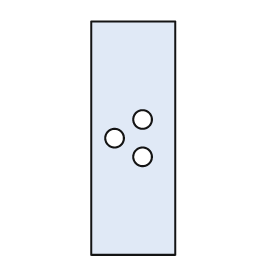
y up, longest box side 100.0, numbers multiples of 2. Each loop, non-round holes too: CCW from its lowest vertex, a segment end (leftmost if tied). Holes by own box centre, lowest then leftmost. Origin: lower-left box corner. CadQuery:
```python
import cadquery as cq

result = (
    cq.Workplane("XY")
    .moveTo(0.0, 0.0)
    .lineTo(36.0, 0.0)
    .lineTo(36.0, 100.0)
    .lineTo(0.0, 100.0)
    .close()
    .moveTo(22.0, 42.0)
    .circle(4.0)
    .moveTo(10.0, 50.0)
    .circle(4.0)
    .moveTo(22.0, 58.0)
    .circle(4.0)
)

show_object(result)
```